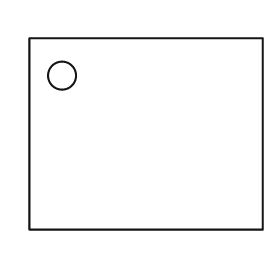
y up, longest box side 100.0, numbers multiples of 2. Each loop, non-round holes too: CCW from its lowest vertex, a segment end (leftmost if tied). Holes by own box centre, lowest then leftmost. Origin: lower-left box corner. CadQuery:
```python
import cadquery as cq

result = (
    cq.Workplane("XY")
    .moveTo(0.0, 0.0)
    .lineTo(100.0, 0.0)
    .lineTo(100.0, 82.0)
    .lineTo(0.0, 82.0)
    .close()
    .moveTo(14.0, 66.0)
    .circle(6.0)
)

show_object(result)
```